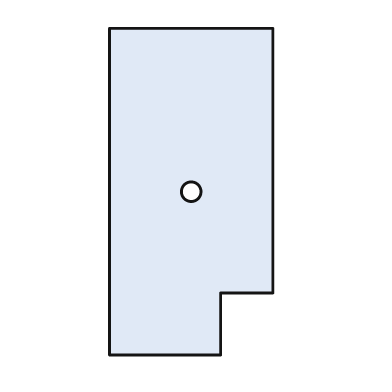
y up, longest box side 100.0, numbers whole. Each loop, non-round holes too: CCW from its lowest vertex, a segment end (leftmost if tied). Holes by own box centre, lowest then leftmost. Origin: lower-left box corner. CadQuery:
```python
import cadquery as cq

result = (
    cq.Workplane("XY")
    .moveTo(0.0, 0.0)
    .lineTo(34.0, 0.0)
    .lineTo(34.0, 19.0)
    .lineTo(50.0, 19.0)
    .lineTo(50.0, 100.0)
    .lineTo(0.0, 100.0)
    .close()
    .moveTo(25.0, 50.0)
    .circle(3.0)
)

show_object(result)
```